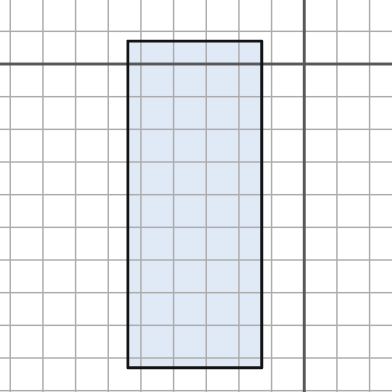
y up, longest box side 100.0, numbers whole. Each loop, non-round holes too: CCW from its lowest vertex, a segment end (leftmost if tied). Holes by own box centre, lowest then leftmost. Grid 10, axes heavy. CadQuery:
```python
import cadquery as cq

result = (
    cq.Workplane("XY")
    .moveTo(-54.0, -93.0)
    .lineTo(-13.0, -93.0)
    .lineTo(-13.0, 7.0)
    .lineTo(-54.0, 7.0)
    .close()
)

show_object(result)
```